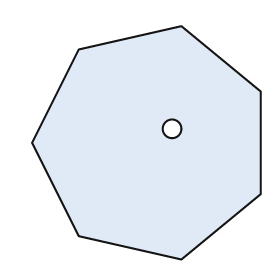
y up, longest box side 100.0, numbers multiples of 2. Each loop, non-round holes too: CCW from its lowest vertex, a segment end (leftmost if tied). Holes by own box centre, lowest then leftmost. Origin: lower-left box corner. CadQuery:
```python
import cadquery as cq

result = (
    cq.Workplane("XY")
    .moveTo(64.0, 0.0)
    .lineTo(98.0, 28.0)
    .lineTo(98.0, 72.0)
    .lineTo(64.0, 100.0)
    .lineTo(20.0, 90.0)
    .lineTo(0.0, 50.0)
    .lineTo(20.0, 10.0)
    .close()
    .moveTo(60.0, 56.0)
    .circle(4.0)
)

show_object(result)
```